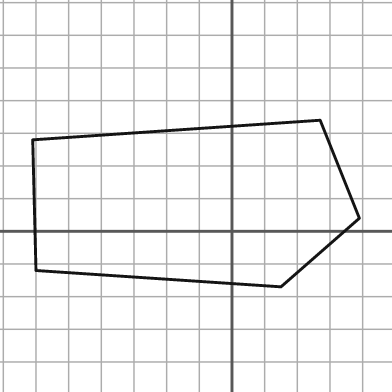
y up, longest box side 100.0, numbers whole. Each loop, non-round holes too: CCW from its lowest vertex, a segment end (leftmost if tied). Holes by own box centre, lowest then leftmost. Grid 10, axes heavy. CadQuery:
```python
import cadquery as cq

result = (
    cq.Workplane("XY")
    .moveTo(15.0, -17.0)
    .lineTo(39.0, 4.0)
    .lineTo(27.0, 34.0)
    .lineTo(-61.0, 28.0)
    .lineTo(-60.0, -12.0)
    .close()
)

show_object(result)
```